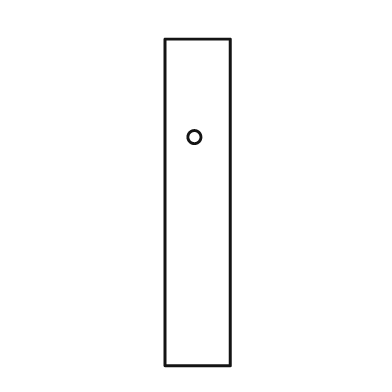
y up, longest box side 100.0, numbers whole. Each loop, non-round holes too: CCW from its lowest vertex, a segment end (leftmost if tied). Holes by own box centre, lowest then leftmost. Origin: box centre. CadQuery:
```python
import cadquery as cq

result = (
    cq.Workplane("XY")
    .moveTo(-10.0, -50.0)
    .lineTo(10.0, -50.0)
    .lineTo(10.0, 50.0)
    .lineTo(-10.0, 50.0)
    .close()
    .moveTo(-1.0, 20.0)
    .circle(2.0)
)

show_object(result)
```